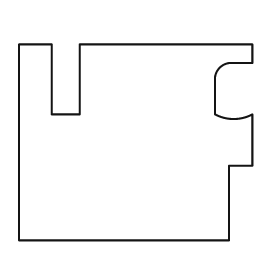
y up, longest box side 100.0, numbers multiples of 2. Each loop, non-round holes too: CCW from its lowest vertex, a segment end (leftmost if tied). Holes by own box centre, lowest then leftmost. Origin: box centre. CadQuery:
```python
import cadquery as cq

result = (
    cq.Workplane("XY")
    .moveTo(-50.0, -42.0)
    .lineTo(40.0, -42.0)
    .lineTo(40.0, -10.0)
    .lineTo(50.0, -10.0)
    .lineTo(50.0, 12.0)
    .threePointArc((42.0, 10.0), (34.0, 12.0))
    .lineTo(34.0, 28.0)
    .threePointArc((36.0, 32.0), (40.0, 34.0))
    .lineTo(50.0, 34.0)
    .lineTo(50.0, 42.0)
    .lineTo(-24.0, 42.0)
    .lineTo(-24.0, 12.0)
    .lineTo(-36.0, 12.0)
    .lineTo(-36.0, 42.0)
    .lineTo(-50.0, 42.0)
    .close()
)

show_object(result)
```